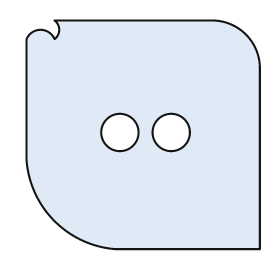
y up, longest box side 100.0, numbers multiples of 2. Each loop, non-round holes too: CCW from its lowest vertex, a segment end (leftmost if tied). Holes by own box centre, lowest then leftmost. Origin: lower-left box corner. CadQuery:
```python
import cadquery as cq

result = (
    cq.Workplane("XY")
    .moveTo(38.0, 0.0)
    .lineTo(100.0, 0.0)
    .lineTo(100.0, 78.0)
    .threePointArc((94.0, 92.0), (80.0, 98.0))
    .lineTo(12.0, 98.0)
    .threePointArc((14.0, 94.0), (12.0, 90.0))
    .threePointArc((6.0, 94.0), (0.0, 90.0))
    .lineTo(0.0, 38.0)
    .threePointArc((12.0, 12.0), (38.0, 0.0))
    .close()
    .moveTo(40.0, 50.0)
    .circle(8.0)
    .moveTo(62.0, 50.0)
    .circle(8.0)
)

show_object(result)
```